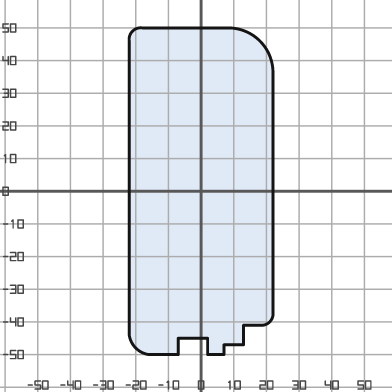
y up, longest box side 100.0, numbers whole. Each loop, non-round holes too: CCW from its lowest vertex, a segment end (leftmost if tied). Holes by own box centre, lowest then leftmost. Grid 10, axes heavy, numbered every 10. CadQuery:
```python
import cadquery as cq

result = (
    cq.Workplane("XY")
    .moveTo(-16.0, -50.0)
    .lineTo(-7.0, -50.0)
    .lineTo(-7.0, -45.0)
    .lineTo(2.0, -45.0)
    .lineTo(2.0, -50.0)
    .lineTo(7.0, -50.0)
    .lineTo(7.0, -47.0)
    .lineTo(13.0, -47.0)
    .lineTo(13.0, -41.0)
    .lineTo(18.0, -41.0)
    .threePointArc((21.0, -40.0), (22.0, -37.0))
    .lineTo(22.0, 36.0)
    .threePointArc((18.0, 46.0), (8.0, 50.0))
    .lineTo(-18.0, 50.0)
    .threePointArc((-21.0, 49.0), (-22.0, 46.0))
    .lineTo(-22.0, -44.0)
    .threePointArc((-20.0, -48.0), (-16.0, -50.0))
    .close()
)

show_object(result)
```